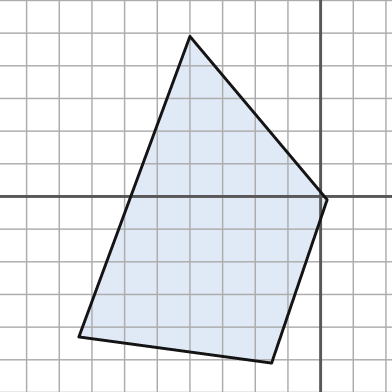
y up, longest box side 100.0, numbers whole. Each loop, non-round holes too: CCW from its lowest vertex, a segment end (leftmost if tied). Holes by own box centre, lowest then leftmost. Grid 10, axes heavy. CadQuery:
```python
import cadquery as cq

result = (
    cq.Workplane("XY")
    .moveTo(-15.0, -51.0)
    .lineTo(2.0, -1.0)
    .lineTo(-40.0, 49.0)
    .lineTo(-74.0, -43.0)
    .close()
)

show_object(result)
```